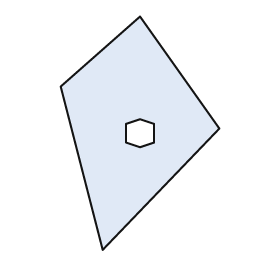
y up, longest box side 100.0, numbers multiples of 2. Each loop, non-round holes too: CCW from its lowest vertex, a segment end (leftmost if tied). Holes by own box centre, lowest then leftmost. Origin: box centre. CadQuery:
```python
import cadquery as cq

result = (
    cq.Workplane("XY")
    .moveTo(-16.0, -50.0)
    .lineTo(34.0, 2.0)
    .lineTo(0.0, 50.0)
    .lineTo(-34.0, 20.0)
    .close()
    .moveTo(0.0, -6.0)
    .lineTo(6.0, -4.0)
    .lineTo(6.0, 4.0)
    .lineTo(0.0, 6.0)
    .lineTo(-6.0, 4.0)
    .lineTo(-6.0, -4.0)
    .close()
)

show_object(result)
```